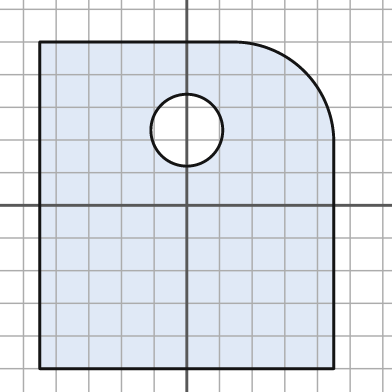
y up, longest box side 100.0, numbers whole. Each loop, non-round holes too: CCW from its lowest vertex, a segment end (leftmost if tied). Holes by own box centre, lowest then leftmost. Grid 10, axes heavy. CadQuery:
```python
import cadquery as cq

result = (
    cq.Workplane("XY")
    .moveTo(-45.0, -50.0)
    .lineTo(45.0, -50.0)
    .lineTo(45.0, 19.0)
    .threePointArc((36.0, 41.0), (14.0, 50.0))
    .lineTo(-45.0, 50.0)
    .close()
    .moveTo(0.0, 23.0)
    .circle(11.0)
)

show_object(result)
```